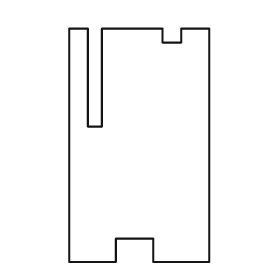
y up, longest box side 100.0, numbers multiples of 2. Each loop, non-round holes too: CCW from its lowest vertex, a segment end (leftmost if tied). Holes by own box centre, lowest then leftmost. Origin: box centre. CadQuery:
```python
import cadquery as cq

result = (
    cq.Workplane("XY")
    .moveTo(-30.0, -50.0)
    .lineTo(-10.0, -50.0)
    .lineTo(-10.0, -40.0)
    .lineTo(6.0, -40.0)
    .lineTo(6.0, -50.0)
    .lineTo(30.0, -50.0)
    .lineTo(30.0, 50.0)
    .lineTo(18.0, 50.0)
    .lineTo(18.0, 44.0)
    .lineTo(10.0, 44.0)
    .lineTo(10.0, 50.0)
    .lineTo(-16.0, 50.0)
    .lineTo(-16.0, 8.0)
    .lineTo(-22.0, 8.0)
    .lineTo(-22.0, 50.0)
    .lineTo(-30.0, 50.0)
    .close()
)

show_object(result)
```